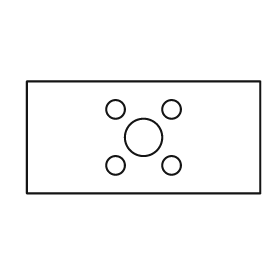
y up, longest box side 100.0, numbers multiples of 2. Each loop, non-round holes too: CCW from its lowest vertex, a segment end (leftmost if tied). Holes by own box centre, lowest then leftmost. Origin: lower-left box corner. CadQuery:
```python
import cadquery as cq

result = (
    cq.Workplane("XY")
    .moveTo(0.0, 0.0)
    .lineTo(100.0, 0.0)
    .lineTo(100.0, 48.0)
    .lineTo(0.0, 48.0)
    .close()
    .moveTo(38.0, 12.0)
    .circle(4.0)
    .moveTo(62.0, 12.0)
    .circle(4.0)
    .moveTo(50.0, 24.0)
    .circle(8.0)
    .moveTo(38.0, 36.0)
    .circle(4.0)
    .moveTo(62.0, 36.0)
    .circle(4.0)
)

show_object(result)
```